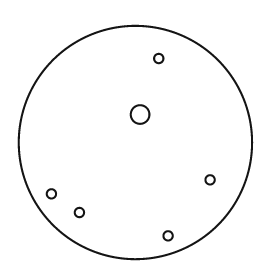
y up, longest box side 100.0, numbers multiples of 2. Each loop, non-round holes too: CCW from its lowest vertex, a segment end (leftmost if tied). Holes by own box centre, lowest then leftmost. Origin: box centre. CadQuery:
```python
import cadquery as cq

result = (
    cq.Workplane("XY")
    .moveTo(0.0, 0.0)
    .circle(50.0)
    .moveTo(14.0, -40.0)
    .circle(2.0)
    .moveTo(-24.0, -30.0)
    .circle(2.0)
    .moveTo(-36.0, -22.0)
    .circle(2.0)
    .moveTo(32.0, -16.0)
    .circle(2.0)
    .moveTo(2.0, 12.0)
    .circle(4.0)
    .moveTo(10.0, 36.0)
    .circle(2.0)
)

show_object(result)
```